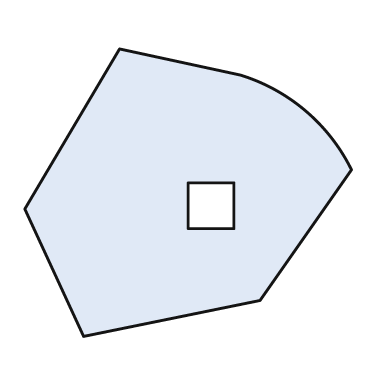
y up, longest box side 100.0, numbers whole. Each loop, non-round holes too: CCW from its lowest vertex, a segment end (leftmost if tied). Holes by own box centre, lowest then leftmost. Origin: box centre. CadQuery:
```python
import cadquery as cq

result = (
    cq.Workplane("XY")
    .moveTo(-32.0, -44.0)
    .lineTo(22.0, -33.0)
    .lineTo(50.0, 7.0)
    .threePointArc((36.0, 25.0), (16.0, 36.0))
    .lineTo(-21.0, 44.0)
    .lineTo(-50.0, -5.0)
    .close()
    .moveTo(0.0, -11.0)
    .lineTo(14.0, -11.0)
    .lineTo(14.0, 3.0)
    .lineTo(0.0, 3.0)
    .close()
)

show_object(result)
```